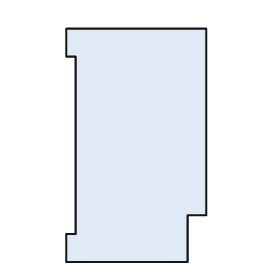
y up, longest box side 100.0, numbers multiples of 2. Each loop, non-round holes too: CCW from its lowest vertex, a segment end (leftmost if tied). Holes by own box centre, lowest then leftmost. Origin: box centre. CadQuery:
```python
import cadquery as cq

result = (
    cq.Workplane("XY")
    .moveTo(-30.0, -50.0)
    .lineTo(22.0, -50.0)
    .lineTo(22.0, -30.0)
    .lineTo(30.0, -30.0)
    .lineTo(30.0, 50.0)
    .lineTo(-30.0, 50.0)
    .lineTo(-30.0, 38.0)
    .lineTo(-26.0, 38.0)
    .lineTo(-26.0, -38.0)
    .lineTo(-30.0, -38.0)
    .close()
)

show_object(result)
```